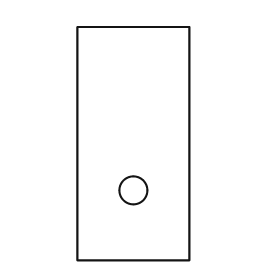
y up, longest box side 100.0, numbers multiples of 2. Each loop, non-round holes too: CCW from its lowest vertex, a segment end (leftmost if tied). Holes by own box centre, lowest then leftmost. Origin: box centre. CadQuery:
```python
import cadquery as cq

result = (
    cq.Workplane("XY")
    .moveTo(-24.0, -50.0)
    .lineTo(24.0, -50.0)
    .lineTo(24.0, 50.0)
    .lineTo(-24.0, 50.0)
    .close()
    .moveTo(0.0, -20.0)
    .circle(6.0)
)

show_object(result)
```